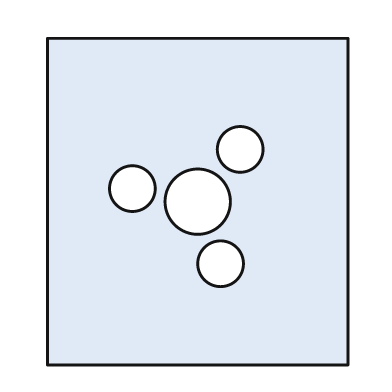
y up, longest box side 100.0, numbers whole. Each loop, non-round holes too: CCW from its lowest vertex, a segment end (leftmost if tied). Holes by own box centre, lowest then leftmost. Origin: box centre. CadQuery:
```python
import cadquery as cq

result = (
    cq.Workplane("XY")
    .moveTo(-46.0, -50.0)
    .lineTo(46.0, -50.0)
    .lineTo(46.0, 50.0)
    .lineTo(-46.0, 50.0)
    .close()
    .moveTo(7.0, -19.0)
    .circle(7.0)
    .moveTo(0.0, 0.0)
    .circle(10.0)
    .moveTo(-20.0, 4.0)
    .circle(7.0)
    .moveTo(13.0, 16.0)
    .circle(7.0)
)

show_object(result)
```